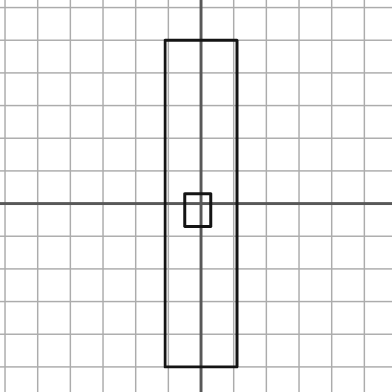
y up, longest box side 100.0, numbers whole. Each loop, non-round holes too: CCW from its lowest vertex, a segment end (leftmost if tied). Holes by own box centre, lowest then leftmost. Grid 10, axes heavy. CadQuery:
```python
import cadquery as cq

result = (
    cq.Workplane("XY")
    .moveTo(-11.0, -50.0)
    .lineTo(11.0, -50.0)
    .lineTo(11.0, 50.0)
    .lineTo(-11.0, 50.0)
    .close()
    .moveTo(-5.0, -7.0)
    .lineTo(3.0, -7.0)
    .lineTo(3.0, 3.0)
    .lineTo(-5.0, 3.0)
    .close()
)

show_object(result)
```